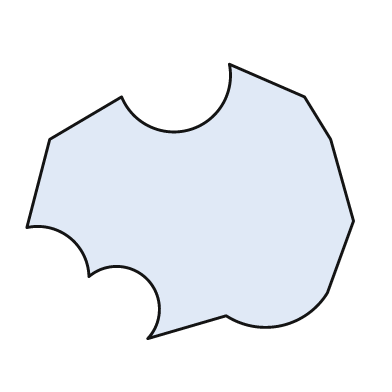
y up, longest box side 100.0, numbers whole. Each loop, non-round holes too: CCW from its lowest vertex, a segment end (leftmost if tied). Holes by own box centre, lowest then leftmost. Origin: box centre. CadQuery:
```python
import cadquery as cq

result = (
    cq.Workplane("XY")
    .moveTo(-13.0, -42.0)
    .lineTo(11.0, -35.0)
    .threePointArc((28.0, -38.0), (42.0, -28.0))
    .lineTo(50.0, -6.0)
    .lineTo(43.0, 19.0)
    .lineTo(35.0, 32.0)
    .lineTo(12.0, 42.0)
    .threePointArc((0.0, 22.0), (-21.0, 32.0))
    .lineTo(-43.0, 19.0)
    .lineTo(-50.0, -8.0)
    .threePointArc((-37.0, -11.0), (-31.0, -23.0))
    .threePointArc((-13.0, -24.0), (-13.0, -42.0))
    .close()
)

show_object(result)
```